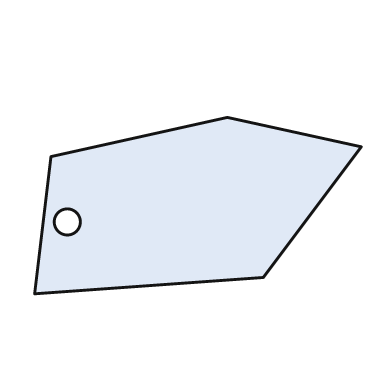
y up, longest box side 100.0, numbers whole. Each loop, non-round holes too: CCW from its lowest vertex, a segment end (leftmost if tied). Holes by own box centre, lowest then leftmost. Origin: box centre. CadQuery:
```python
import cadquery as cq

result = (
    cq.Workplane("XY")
    .moveTo(-50.0, -27.0)
    .lineTo(20.0, -22.0)
    .lineTo(50.0, 18.0)
    .lineTo(9.0, 27.0)
    .lineTo(-45.0, 15.0)
    .close()
    .moveTo(-40.0, -5.0)
    .circle(4.0)
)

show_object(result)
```